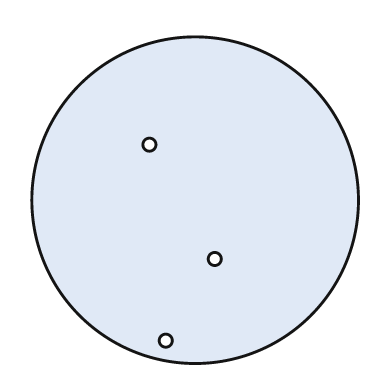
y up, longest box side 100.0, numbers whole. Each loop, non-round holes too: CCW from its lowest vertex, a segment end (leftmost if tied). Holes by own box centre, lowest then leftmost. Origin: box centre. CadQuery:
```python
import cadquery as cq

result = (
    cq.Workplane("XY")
    .moveTo(0.0, 0.0)
    .circle(50.0)
    .moveTo(-9.0, -43.0)
    .circle(2.0)
    .moveTo(6.0, -18.0)
    .circle(2.0)
    .moveTo(-14.0, 17.0)
    .circle(2.0)
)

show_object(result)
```